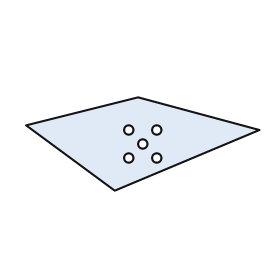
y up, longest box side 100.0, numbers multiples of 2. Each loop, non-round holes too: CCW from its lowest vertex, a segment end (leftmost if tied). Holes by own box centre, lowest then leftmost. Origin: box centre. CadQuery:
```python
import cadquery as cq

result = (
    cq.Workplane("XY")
    .moveTo(-12.0, -20.0)
    .lineTo(50.0, 6.0)
    .lineTo(-2.0, 20.0)
    .lineTo(-50.0, 8.0)
    .close()
    .moveTo(-6.0, -6.0)
    .circle(2.0)
    .moveTo(6.0, -6.0)
    .circle(2.0)
    .moveTo(0.0, 0.0)
    .circle(2.0)
    .moveTo(-6.0, 6.0)
    .circle(2.0)
    .moveTo(6.0, 6.0)
    .circle(2.0)
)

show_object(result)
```